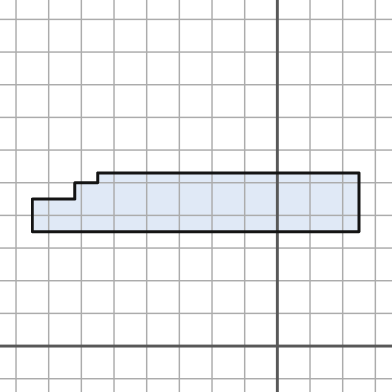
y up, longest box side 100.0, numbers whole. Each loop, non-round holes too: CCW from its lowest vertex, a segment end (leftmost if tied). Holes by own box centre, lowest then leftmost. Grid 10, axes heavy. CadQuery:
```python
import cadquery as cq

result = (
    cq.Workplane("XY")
    .moveTo(-75.0, 35.0)
    .lineTo(25.0, 35.0)
    .lineTo(25.0, 53.0)
    .lineTo(-55.0, 53.0)
    .lineTo(-55.0, 50.0)
    .lineTo(-62.0, 50.0)
    .lineTo(-62.0, 45.0)
    .lineTo(-75.0, 45.0)
    .close()
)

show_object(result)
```